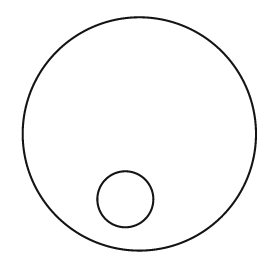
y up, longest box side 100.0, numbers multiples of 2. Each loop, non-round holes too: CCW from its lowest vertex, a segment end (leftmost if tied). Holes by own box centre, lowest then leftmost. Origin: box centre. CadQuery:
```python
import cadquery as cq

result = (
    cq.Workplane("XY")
    .moveTo(0.0, 0.0)
    .circle(50.0)
    .moveTo(-6.0, -28.0)
    .circle(12.0)
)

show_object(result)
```